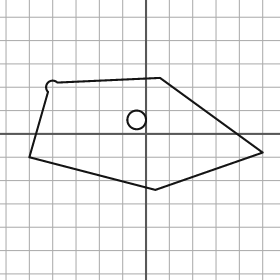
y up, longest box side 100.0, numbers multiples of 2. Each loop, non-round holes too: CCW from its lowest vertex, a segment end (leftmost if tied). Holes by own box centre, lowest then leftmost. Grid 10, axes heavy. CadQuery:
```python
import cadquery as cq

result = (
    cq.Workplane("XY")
    .moveTo(4.0, -24.0)
    .lineTo(50.0, -8.0)
    .lineTo(6.0, 24.0)
    .lineTo(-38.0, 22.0)
    .threePointArc((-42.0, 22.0), (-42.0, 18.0))
    .lineTo(-50.0, -10.0)
    .close()
    .moveTo(-4.0, 6.0)
    .circle(4.0)
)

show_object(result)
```